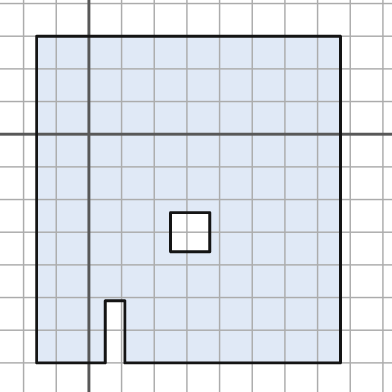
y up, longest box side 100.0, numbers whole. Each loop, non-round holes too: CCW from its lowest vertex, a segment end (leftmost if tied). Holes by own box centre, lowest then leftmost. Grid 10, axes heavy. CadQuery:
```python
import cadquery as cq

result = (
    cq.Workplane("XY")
    .moveTo(-16.0, -70.0)
    .lineTo(5.0, -70.0)
    .lineTo(5.0, -51.0)
    .lineTo(11.0, -51.0)
    .lineTo(11.0, -70.0)
    .lineTo(77.0, -70.0)
    .lineTo(77.0, 30.0)
    .lineTo(-16.0, 30.0)
    .close()
    .moveTo(25.0, -36.0)
    .lineTo(37.0, -36.0)
    .lineTo(37.0, -24.0)
    .lineTo(25.0, -24.0)
    .close()
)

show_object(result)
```